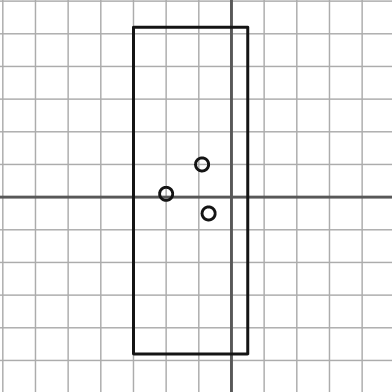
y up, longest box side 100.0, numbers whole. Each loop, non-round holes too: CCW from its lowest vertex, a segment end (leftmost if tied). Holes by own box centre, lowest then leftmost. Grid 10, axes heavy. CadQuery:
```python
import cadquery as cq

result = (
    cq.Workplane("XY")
    .moveTo(-30.0, -48.0)
    .lineTo(5.0, -48.0)
    .lineTo(5.0, 52.0)
    .lineTo(-30.0, 52.0)
    .close()
    .moveTo(-7.0, -5.0)
    .circle(2.0)
    .moveTo(-20.0, 1.0)
    .circle(2.0)
    .moveTo(-9.0, 10.0)
    .circle(2.0)
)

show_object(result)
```